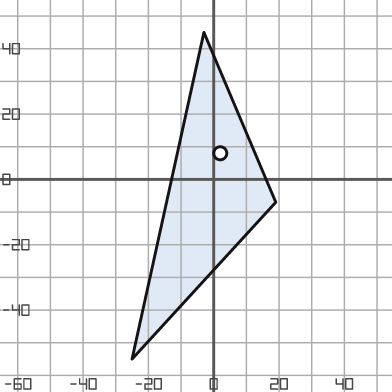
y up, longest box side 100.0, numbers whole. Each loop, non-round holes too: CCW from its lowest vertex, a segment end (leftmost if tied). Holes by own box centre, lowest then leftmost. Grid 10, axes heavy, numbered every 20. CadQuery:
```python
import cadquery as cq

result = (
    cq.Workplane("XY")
    .moveTo(-25.0, -55.0)
    .lineTo(19.0, -7.0)
    .lineTo(-3.0, 45.0)
    .close()
    .moveTo(2.0, 8.0)
    .circle(2.0)
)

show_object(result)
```